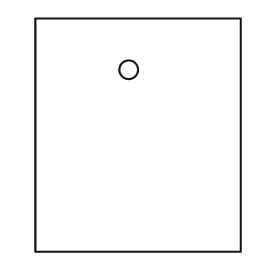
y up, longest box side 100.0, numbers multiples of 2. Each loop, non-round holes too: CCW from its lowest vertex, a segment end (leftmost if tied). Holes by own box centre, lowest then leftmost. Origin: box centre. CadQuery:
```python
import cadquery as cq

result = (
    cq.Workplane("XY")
    .moveTo(-44.0, -50.0)
    .lineTo(44.0, -50.0)
    .lineTo(44.0, 50.0)
    .lineTo(-44.0, 50.0)
    .close()
    .moveTo(-4.0, 28.0)
    .circle(4.0)
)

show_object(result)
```